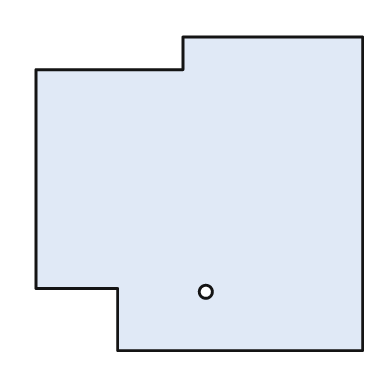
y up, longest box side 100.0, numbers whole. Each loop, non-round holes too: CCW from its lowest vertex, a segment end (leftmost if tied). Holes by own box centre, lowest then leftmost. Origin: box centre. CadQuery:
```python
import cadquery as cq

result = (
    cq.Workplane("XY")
    .moveTo(-25.0, -48.0)
    .lineTo(50.0, -48.0)
    .lineTo(50.0, 48.0)
    .lineTo(-5.0, 48.0)
    .lineTo(-5.0, 38.0)
    .lineTo(-50.0, 38.0)
    .lineTo(-50.0, -29.0)
    .lineTo(-25.0, -29.0)
    .close()
    .moveTo(2.0, -30.0)
    .circle(2.0)
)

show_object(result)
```